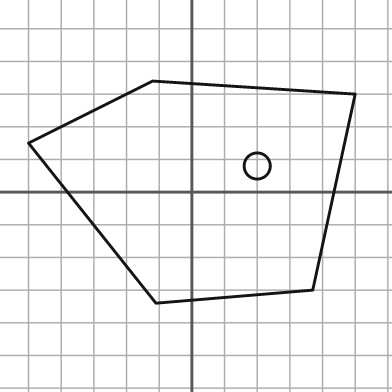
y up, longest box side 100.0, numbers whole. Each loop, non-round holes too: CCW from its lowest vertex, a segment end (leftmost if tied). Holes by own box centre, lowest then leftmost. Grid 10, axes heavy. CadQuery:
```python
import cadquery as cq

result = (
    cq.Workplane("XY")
    .moveTo(-11.0, -34.0)
    .lineTo(37.0, -30.0)
    .lineTo(50.0, 30.0)
    .lineTo(-12.0, 34.0)
    .lineTo(-50.0, 15.0)
    .close()
    .moveTo(20.0, 8.0)
    .circle(4.0)
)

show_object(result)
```